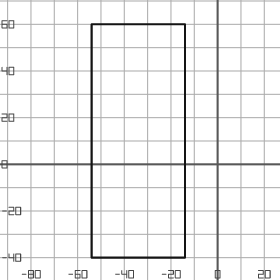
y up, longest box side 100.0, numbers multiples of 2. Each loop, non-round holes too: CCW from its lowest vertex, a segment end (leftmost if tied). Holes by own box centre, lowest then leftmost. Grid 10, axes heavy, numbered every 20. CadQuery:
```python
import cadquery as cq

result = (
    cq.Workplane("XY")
    .moveTo(-54.0, -40.0)
    .lineTo(-14.0, -40.0)
    .lineTo(-14.0, 60.0)
    .lineTo(-54.0, 60.0)
    .close()
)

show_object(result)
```